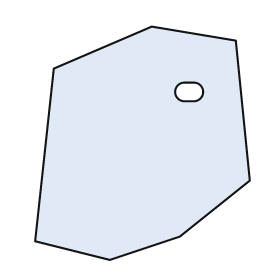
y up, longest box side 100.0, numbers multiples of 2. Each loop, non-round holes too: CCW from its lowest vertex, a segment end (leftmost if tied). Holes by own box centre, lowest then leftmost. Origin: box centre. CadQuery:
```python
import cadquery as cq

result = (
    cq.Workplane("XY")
    .moveTo(-14.0, -50.0)
    .lineTo(16.0, -40.0)
    .lineTo(46.0, -16.0)
    .lineTo(40.0, 44.0)
    .lineTo(4.0, 50.0)
    .lineTo(-38.0, 32.0)
    .lineTo(-46.0, -42.0)
    .close()
    .moveTo(18.0, 18.0)
    .lineTo(22.0, 18.0)
    .threePointArc((26.0, 22.0), (22.0, 26.0))
    .lineTo(18.0, 26.0)
    .threePointArc((14.0, 22.0), (18.0, 18.0))
    .close()
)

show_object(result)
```